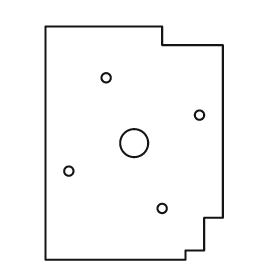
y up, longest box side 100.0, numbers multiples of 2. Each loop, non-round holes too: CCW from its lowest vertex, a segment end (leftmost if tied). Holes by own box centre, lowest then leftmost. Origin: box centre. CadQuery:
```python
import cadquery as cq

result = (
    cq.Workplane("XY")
    .moveTo(-38.0, -50.0)
    .lineTo(22.0, -50.0)
    .lineTo(22.0, -46.0)
    .lineTo(30.0, -46.0)
    .lineTo(30.0, -32.0)
    .lineTo(38.0, -32.0)
    .lineTo(38.0, 42.0)
    .lineTo(12.0, 42.0)
    .lineTo(12.0, 50.0)
    .lineTo(-38.0, 50.0)
    .close()
    .moveTo(12.0, -28.0)
    .circle(2.0)
    .moveTo(-28.0, -12.0)
    .circle(2.0)
    .moveTo(0.0, 0.0)
    .circle(6.0)
    .moveTo(28.0, 12.0)
    .circle(2.0)
    .moveTo(-12.0, 28.0)
    .circle(2.0)
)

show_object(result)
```